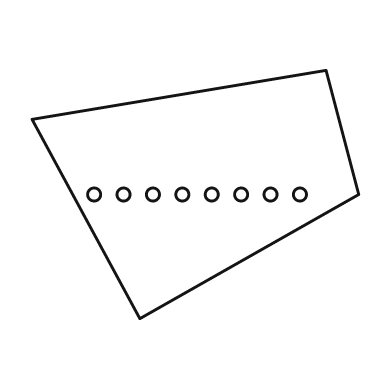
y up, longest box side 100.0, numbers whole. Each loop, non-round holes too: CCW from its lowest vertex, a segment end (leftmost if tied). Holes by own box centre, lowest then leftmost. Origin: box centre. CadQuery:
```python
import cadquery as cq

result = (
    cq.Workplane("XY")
    .moveTo(-17.0, -38.0)
    .lineTo(50.0, 0.0)
    .lineTo(40.0, 38.0)
    .lineTo(-50.0, 23.0)
    .close()
    .moveTo(-31.0, 0.0)
    .circle(2.0)
    .moveTo(-22.0, 0.0)
    .circle(2.0)
    .moveTo(-13.0, 0.0)
    .circle(2.0)
    .moveTo(-4.0, 0.0)
    .circle(2.0)
    .moveTo(5.0, 0.0)
    .circle(2.0)
    .moveTo(14.0, 0.0)
    .circle(2.0)
    .moveTo(23.0, 0.0)
    .circle(2.0)
    .moveTo(32.0, 0.0)
    .circle(2.0)
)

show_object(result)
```